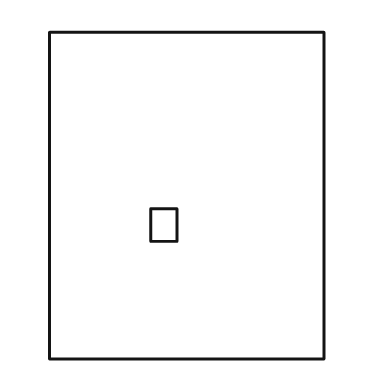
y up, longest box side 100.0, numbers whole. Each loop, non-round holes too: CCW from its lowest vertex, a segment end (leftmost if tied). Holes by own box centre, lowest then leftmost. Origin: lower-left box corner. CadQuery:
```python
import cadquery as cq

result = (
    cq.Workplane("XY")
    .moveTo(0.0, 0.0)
    .lineTo(84.0, 0.0)
    .lineTo(84.0, 100.0)
    .lineTo(0.0, 100.0)
    .close()
    .moveTo(31.0, 36.0)
    .lineTo(39.0, 36.0)
    .lineTo(39.0, 46.0)
    .lineTo(31.0, 46.0)
    .close()
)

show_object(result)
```